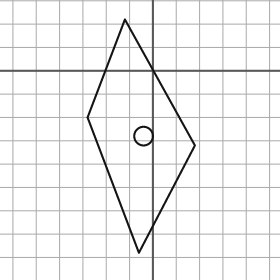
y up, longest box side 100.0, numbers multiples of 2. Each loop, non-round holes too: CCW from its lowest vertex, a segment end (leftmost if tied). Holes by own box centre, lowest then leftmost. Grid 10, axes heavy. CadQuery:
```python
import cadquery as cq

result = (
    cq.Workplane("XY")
    .moveTo(-6.0, -78.0)
    .lineTo(18.0, -32.0)
    .lineTo(-12.0, 22.0)
    .lineTo(-28.0, -20.0)
    .close()
    .moveTo(-4.0, -28.0)
    .circle(4.0)
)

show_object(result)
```